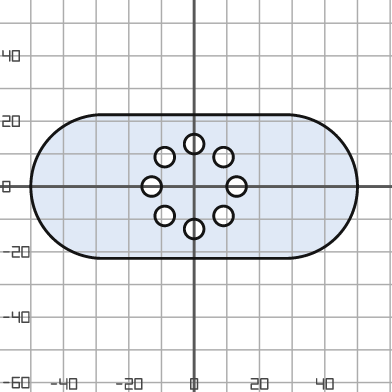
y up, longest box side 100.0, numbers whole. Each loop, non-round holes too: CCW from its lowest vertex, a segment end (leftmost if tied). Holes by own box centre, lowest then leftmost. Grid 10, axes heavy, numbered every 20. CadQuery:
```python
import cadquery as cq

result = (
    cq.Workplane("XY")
    .moveTo(-28.0, -22.0)
    .lineTo(28.0, -22.0)
    .threePointArc((50.0, 0.0), (28.0, 22.0))
    .lineTo(-28.0, 22.0)
    .threePointArc((-50.0, 0.0), (-28.0, -22.0))
    .close()
    .moveTo(0.0, -13.0)
    .circle(3.0)
    .moveTo(-9.0, -9.0)
    .circle(3.0)
    .moveTo(9.0, -9.0)
    .circle(3.0)
    .moveTo(-13.0, 0.0)
    .circle(3.0)
    .moveTo(13.0, 0.0)
    .circle(3.0)
    .moveTo(-9.0, 9.0)
    .circle(3.0)
    .moveTo(9.0, 9.0)
    .circle(3.0)
    .moveTo(0.0, 13.0)
    .circle(3.0)
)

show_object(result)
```